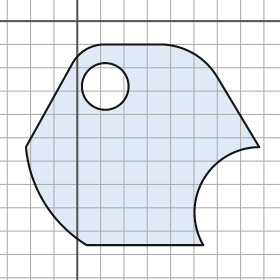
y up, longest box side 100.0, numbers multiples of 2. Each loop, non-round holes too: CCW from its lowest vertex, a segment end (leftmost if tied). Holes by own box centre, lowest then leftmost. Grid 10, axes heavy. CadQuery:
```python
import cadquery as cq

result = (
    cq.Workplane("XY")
    .moveTo(4.0, -96.0)
    .lineTo(54.0, -96.0)
    .threePointArc((54.0, -68.0), (78.0, -54.0))
    .lineTo(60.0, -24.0)
    .threePointArc((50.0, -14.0), (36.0, -10.0))
    .lineTo(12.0, -10.0)
    .threePointArc((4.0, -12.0), (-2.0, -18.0))
    .lineTo(-22.0, -54.0)
    .threePointArc((-14.0, -78.0), (4.0, -96.0))
    .close()
    .moveTo(12.0, -28.0)
    .circle(10.0)
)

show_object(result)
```